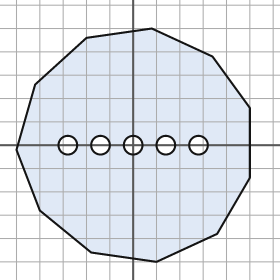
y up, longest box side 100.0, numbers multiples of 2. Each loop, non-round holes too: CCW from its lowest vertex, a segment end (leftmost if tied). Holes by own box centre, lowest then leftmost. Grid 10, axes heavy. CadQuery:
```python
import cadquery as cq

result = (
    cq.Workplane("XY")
    .moveTo(10.0, -50.0)
    .lineTo(36.0, -38.0)
    .lineTo(50.0, -14.0)
    .lineTo(50.0, 16.0)
    .lineTo(34.0, 38.0)
    .lineTo(8.0, 50.0)
    .lineTo(-20.0, 46.0)
    .lineTo(-42.0, 26.0)
    .lineTo(-50.0, -2.0)
    .lineTo(-40.0, -28.0)
    .lineTo(-18.0, -46.0)
    .close()
    .moveTo(-28.0, 0.0)
    .circle(4.0)
    .moveTo(-14.0, 0.0)
    .circle(4.0)
    .moveTo(0.0, 0.0)
    .circle(4.0)
    .moveTo(14.0, 0.0)
    .circle(4.0)
    .moveTo(28.0, 0.0)
    .circle(4.0)
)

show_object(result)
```